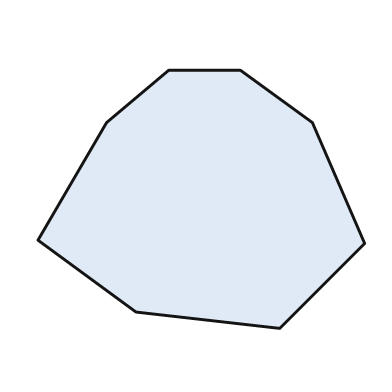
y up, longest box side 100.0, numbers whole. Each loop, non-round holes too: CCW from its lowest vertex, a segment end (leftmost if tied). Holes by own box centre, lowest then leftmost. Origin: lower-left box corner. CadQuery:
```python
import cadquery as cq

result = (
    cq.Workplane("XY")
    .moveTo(74.0, 0.0)
    .lineTo(100.0, 26.0)
    .lineTo(84.0, 63.0)
    .lineTo(62.0, 79.0)
    .lineTo(40.0, 79.0)
    .lineTo(21.0, 63.0)
    .lineTo(0.0, 27.0)
    .lineTo(30.0, 5.0)
    .close()
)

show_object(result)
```